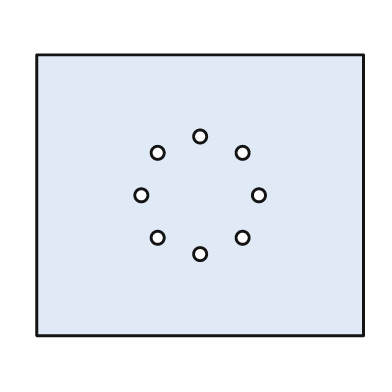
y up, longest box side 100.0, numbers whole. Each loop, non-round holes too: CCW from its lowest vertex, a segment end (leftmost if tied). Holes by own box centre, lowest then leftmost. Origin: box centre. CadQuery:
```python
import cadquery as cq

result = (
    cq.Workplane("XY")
    .moveTo(-50.0, -43.0)
    .lineTo(50.0, -43.0)
    .lineTo(50.0, 43.0)
    .lineTo(-50.0, 43.0)
    .close()
    .moveTo(0.0, -18.0)
    .circle(2.0)
    .moveTo(-13.0, -13.0)
    .circle(2.0)
    .moveTo(13.0, -13.0)
    .circle(2.0)
    .moveTo(-18.0, 0.0)
    .circle(2.0)
    .moveTo(18.0, 0.0)
    .circle(2.0)
    .moveTo(-13.0, 13.0)
    .circle(2.0)
    .moveTo(13.0, 13.0)
    .circle(2.0)
    .moveTo(0.0, 18.0)
    .circle(2.0)
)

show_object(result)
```